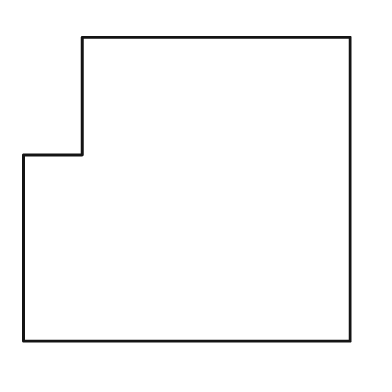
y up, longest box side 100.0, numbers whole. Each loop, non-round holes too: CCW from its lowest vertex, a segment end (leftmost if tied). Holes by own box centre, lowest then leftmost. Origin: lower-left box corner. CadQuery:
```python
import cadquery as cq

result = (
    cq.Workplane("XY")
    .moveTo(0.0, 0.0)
    .lineTo(100.0, 0.0)
    .lineTo(100.0, 93.0)
    .lineTo(18.0, 93.0)
    .lineTo(18.0, 57.0)
    .lineTo(0.0, 57.0)
    .close()
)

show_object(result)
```